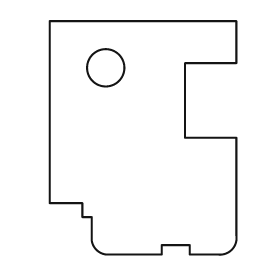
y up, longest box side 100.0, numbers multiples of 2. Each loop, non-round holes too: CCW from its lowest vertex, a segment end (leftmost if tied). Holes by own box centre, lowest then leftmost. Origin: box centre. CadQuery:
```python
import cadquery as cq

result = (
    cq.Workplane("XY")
    .moveTo(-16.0, -50.0)
    .lineTo(8.0, -50.0)
    .lineTo(8.0, -46.0)
    .lineTo(20.0, -46.0)
    .lineTo(20.0, -50.0)
    .lineTo(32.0, -50.0)
    .threePointArc((38.0, -48.0), (40.0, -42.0))
    .lineTo(40.0, 0.0)
    .lineTo(18.0, 0.0)
    .lineTo(18.0, 32.0)
    .lineTo(40.0, 32.0)
    .lineTo(40.0, 50.0)
    .lineTo(-40.0, 50.0)
    .lineTo(-40.0, -28.0)
    .lineTo(-26.0, -28.0)
    .lineTo(-26.0, -34.0)
    .lineTo(-22.0, -34.0)
    .lineTo(-22.0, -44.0)
    .threePointArc((-20.0, -48.0), (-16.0, -50.0))
    .close()
    .moveTo(-16.0, 30.0)
    .circle(8.0)
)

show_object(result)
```